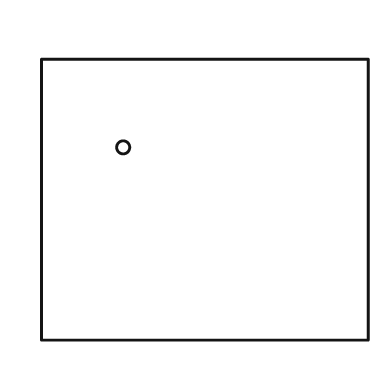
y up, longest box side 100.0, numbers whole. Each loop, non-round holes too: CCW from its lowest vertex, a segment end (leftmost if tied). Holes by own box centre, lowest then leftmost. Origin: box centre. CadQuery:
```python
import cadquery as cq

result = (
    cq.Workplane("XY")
    .moveTo(-50.0, -43.0)
    .lineTo(50.0, -43.0)
    .lineTo(50.0, 43.0)
    .lineTo(-50.0, 43.0)
    .close()
    .moveTo(-25.0, 16.0)
    .circle(2.0)
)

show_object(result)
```